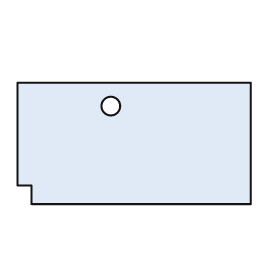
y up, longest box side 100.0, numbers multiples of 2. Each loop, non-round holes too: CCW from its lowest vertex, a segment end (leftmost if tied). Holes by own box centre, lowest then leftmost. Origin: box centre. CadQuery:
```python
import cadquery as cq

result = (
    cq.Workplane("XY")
    .moveTo(-44.0, -26.0)
    .lineTo(50.0, -26.0)
    .lineTo(50.0, 26.0)
    .lineTo(-50.0, 26.0)
    .lineTo(-50.0, -18.0)
    .lineTo(-44.0, -18.0)
    .close()
    .moveTo(-10.0, 16.0)
    .circle(4.0)
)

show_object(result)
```